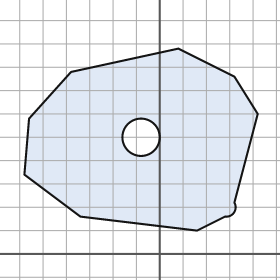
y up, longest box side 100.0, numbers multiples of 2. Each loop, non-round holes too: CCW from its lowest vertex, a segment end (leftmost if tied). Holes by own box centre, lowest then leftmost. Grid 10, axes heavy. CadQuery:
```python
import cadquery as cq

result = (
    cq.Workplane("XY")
    .moveTo(16.0, 10.0)
    .lineTo(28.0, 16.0)
    .threePointArc((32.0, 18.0), (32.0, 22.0))
    .lineTo(42.0, 60.0)
    .lineTo(32.0, 76.0)
    .lineTo(8.0, 88.0)
    .lineTo(-38.0, 78.0)
    .lineTo(-56.0, 58.0)
    .lineTo(-58.0, 34.0)
    .lineTo(-34.0, 16.0)
    .close()
    .moveTo(-8.0, 50.0)
    .circle(8.0)
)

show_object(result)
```